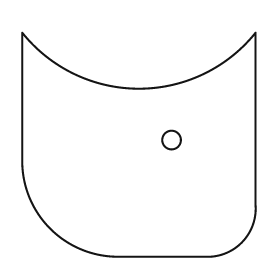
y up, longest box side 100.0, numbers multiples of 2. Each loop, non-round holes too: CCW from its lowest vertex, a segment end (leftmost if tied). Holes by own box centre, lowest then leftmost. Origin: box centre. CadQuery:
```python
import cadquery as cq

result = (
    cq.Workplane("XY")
    .moveTo(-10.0, -48.0)
    .lineTo(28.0, -48.0)
    .threePointArc((44.0, -42.0), (50.0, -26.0))
    .lineTo(50.0, 48.0)
    .threePointArc((0.0, 24.0), (-50.0, 48.0))
    .lineTo(-50.0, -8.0)
    .threePointArc((-38.0, -36.0), (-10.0, -48.0))
    .close()
    .moveTo(14.0, 2.0)
    .circle(4.0)
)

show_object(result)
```